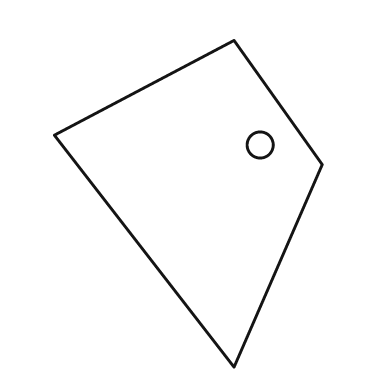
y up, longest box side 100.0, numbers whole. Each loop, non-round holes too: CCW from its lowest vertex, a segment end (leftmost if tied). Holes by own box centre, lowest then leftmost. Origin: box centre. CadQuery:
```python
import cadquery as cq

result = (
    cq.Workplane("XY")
    .moveTo(14.0, -50.0)
    .lineTo(41.0, 12.0)
    .lineTo(14.0, 50.0)
    .lineTo(-41.0, 21.0)
    .close()
    .moveTo(22.0, 18.0)
    .circle(4.0)
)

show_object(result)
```